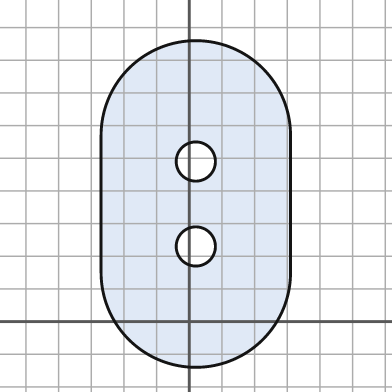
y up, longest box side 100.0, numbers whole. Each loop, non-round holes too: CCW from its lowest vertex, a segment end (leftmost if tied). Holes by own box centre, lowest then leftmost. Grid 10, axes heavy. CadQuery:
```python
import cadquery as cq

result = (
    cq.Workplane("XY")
    .moveTo(-27.0, 15.0)
    .threePointArc((2.0, -14.0), (31.0, 15.0))
    .lineTo(31.0, 57.0)
    .threePointArc((2.0, 86.0), (-27.0, 57.0))
    .close()
    .moveTo(2.0, 23.0)
    .circle(6.0)
    .moveTo(2.0, 49.0)
    .circle(6.0)
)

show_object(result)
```